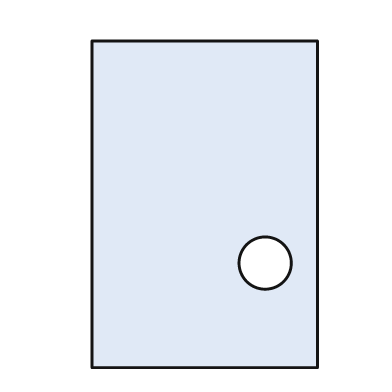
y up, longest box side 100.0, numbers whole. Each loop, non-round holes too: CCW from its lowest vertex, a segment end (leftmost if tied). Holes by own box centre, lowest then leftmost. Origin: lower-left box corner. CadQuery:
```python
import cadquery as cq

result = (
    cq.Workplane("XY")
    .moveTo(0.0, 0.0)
    .lineTo(69.0, 0.0)
    .lineTo(69.0, 100.0)
    .lineTo(0.0, 100.0)
    .close()
    .moveTo(53.0, 32.0)
    .circle(8.0)
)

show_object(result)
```